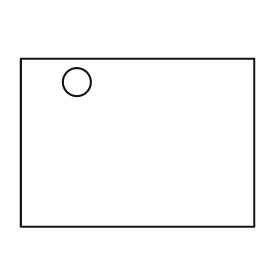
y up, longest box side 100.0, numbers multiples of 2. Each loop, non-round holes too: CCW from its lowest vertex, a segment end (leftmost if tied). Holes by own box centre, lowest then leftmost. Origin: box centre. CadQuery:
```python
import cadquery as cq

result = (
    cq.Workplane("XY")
    .moveTo(-50.0, -36.0)
    .lineTo(50.0, -36.0)
    .lineTo(50.0, 36.0)
    .lineTo(-50.0, 36.0)
    .close()
    .moveTo(-26.0, 26.0)
    .circle(6.0)
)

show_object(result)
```